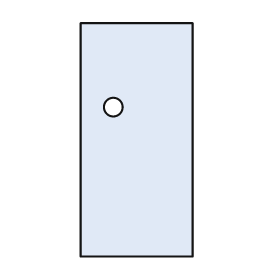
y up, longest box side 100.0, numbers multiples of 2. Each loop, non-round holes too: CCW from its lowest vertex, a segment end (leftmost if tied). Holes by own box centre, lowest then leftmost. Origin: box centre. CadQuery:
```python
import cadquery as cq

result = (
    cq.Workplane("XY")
    .moveTo(-24.0, -50.0)
    .lineTo(24.0, -50.0)
    .lineTo(24.0, 50.0)
    .lineTo(-24.0, 50.0)
    .close()
    .moveTo(-10.0, 14.0)
    .circle(4.0)
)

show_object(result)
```